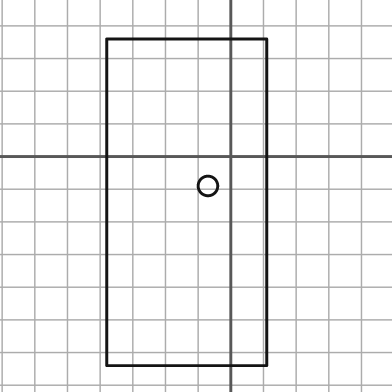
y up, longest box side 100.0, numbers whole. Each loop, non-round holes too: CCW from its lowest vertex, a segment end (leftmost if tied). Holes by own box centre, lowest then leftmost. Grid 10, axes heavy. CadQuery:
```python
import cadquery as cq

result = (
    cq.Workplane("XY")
    .moveTo(-38.0, -64.0)
    .lineTo(11.0, -64.0)
    .lineTo(11.0, 36.0)
    .lineTo(-38.0, 36.0)
    .close()
    .moveTo(-7.0, -9.0)
    .circle(3.0)
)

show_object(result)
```